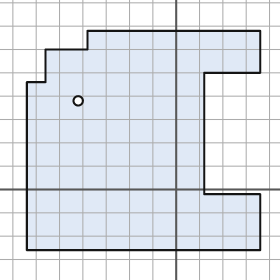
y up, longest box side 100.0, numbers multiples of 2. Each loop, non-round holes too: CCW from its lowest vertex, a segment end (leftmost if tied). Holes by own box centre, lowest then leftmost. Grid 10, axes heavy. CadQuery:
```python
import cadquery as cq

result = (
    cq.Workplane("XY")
    .moveTo(-64.0, -26.0)
    .lineTo(36.0, -26.0)
    .lineTo(36.0, -2.0)
    .lineTo(12.0, -2.0)
    .lineTo(12.0, 50.0)
    .lineTo(36.0, 50.0)
    .lineTo(36.0, 68.0)
    .lineTo(-38.0, 68.0)
    .lineTo(-38.0, 60.0)
    .lineTo(-56.0, 60.0)
    .lineTo(-56.0, 46.0)
    .lineTo(-64.0, 46.0)
    .close()
    .moveTo(-42.0, 38.0)
    .circle(2.0)
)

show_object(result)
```